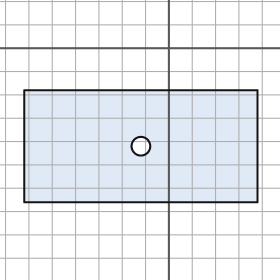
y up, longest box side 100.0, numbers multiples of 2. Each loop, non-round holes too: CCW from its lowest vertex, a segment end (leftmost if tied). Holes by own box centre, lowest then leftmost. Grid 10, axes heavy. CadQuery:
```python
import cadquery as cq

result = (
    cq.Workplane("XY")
    .moveTo(-62.0, -66.0)
    .lineTo(38.0, -66.0)
    .lineTo(38.0, -18.0)
    .lineTo(-62.0, -18.0)
    .close()
    .moveTo(-12.0, -42.0)
    .circle(4.0)
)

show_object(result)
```